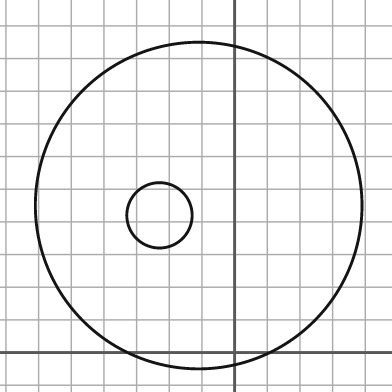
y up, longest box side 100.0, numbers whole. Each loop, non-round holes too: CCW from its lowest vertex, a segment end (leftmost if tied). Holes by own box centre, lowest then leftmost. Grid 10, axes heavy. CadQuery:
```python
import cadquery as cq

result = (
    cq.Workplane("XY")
    .moveTo(-11.0, 45.0)
    .circle(50.0)
    .moveTo(-23.0, 42.0)
    .circle(10.0)
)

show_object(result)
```